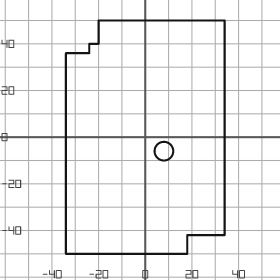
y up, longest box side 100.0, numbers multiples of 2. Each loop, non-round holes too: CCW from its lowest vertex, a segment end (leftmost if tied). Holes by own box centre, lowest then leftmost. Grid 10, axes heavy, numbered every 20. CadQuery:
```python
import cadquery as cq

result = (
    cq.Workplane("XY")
    .moveTo(-34.0, -50.0)
    .lineTo(18.0, -50.0)
    .lineTo(18.0, -42.0)
    .lineTo(34.0, -42.0)
    .lineTo(34.0, 50.0)
    .lineTo(-20.0, 50.0)
    .lineTo(-20.0, 40.0)
    .lineTo(-24.0, 40.0)
    .lineTo(-24.0, 36.0)
    .lineTo(-34.0, 36.0)
    .close()
    .moveTo(8.0, -6.0)
    .circle(4.0)
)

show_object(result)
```